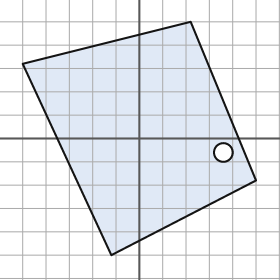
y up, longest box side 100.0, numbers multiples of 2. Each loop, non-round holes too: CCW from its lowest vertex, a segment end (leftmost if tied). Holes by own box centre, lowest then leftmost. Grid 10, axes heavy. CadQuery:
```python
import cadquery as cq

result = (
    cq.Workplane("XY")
    .moveTo(-12.0, -50.0)
    .lineTo(50.0, -18.0)
    .lineTo(22.0, 50.0)
    .lineTo(-50.0, 32.0)
    .close()
    .moveTo(36.0, -6.0)
    .circle(4.0)
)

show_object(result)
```